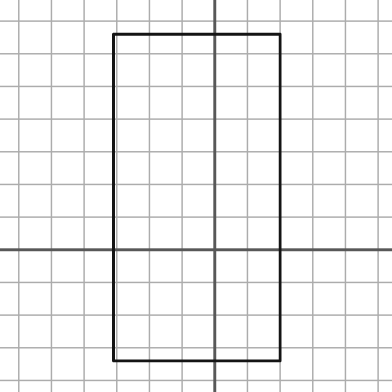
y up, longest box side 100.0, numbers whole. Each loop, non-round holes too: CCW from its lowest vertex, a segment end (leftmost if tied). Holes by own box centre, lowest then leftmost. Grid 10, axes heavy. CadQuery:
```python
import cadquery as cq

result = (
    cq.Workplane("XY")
    .moveTo(-31.0, -34.0)
    .lineTo(20.0, -34.0)
    .lineTo(20.0, 66.0)
    .lineTo(-31.0, 66.0)
    .close()
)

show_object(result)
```